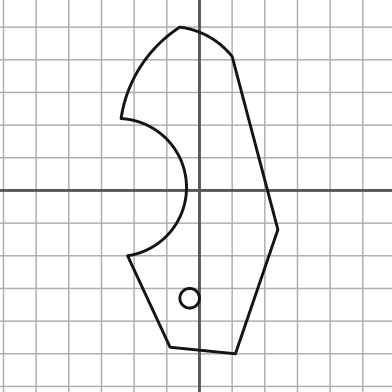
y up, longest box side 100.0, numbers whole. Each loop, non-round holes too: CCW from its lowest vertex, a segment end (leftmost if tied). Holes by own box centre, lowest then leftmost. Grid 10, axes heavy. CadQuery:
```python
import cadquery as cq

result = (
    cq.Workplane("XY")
    .moveTo(11.0, -50.0)
    .lineTo(24.0, -12.0)
    .lineTo(10.0, 41.0)
    .threePointArc((3.0, 47.0), (-6.0, 50.0))
    .threePointArc((-18.0, 38.0), (-24.0, 22.0))
    .threePointArc((-4.0, 2.0), (-22.0, -20.0))
    .lineTo(-9.0, -48.0)
    .close()
    .moveTo(-3.0, -33.0)
    .circle(3.0)
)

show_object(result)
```